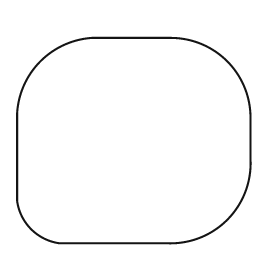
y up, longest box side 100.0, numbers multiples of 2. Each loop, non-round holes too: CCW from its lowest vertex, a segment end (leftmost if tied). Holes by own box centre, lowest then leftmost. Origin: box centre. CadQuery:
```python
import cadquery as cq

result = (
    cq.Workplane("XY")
    .moveTo(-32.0, -44.0)
    .lineTo(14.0, -44.0)
    .threePointArc((40.0, -34.0), (50.0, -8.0))
    .lineTo(50.0, 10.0)
    .threePointArc((40.0, 34.0), (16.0, 44.0))
    .lineTo(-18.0, 44.0)
    .threePointArc((-40.0, 34.0), (-50.0, 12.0))
    .lineTo(-50.0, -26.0)
    .threePointArc((-44.0, -38.0), (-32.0, -44.0))
    .close()
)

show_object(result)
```